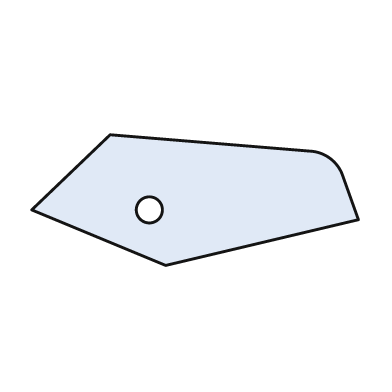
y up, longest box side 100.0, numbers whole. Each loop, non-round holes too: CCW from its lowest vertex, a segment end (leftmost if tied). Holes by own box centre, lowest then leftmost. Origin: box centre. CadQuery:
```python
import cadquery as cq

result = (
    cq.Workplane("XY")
    .moveTo(-9.0, -20.0)
    .lineTo(50.0, -6.0)
    .lineTo(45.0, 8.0)
    .threePointArc((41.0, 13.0), (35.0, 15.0))
    .lineTo(-26.0, 20.0)
    .lineTo(-50.0, -3.0)
    .close()
    .moveTo(-14.0, -3.0)
    .circle(4.0)
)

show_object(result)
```